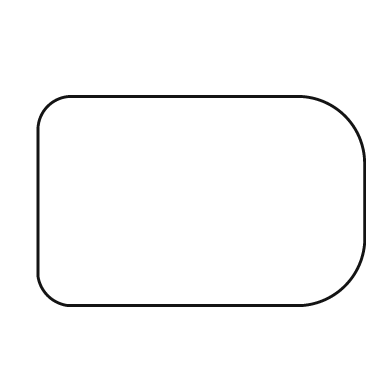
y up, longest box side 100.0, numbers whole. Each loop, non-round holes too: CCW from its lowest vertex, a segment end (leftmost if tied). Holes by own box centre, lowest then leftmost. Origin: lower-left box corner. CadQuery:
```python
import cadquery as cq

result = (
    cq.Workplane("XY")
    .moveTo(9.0, 0.0)
    .lineTo(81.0, 0.0)
    .threePointArc((94.0, 6.0), (100.0, 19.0))
    .lineTo(100.0, 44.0)
    .threePointArc((94.0, 58.0), (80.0, 64.0))
    .lineTo(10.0, 64.0)
    .threePointArc((3.0, 61.0), (0.0, 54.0))
    .lineTo(0.0, 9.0)
    .threePointArc((3.0, 3.0), (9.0, 0.0))
    .close()
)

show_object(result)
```